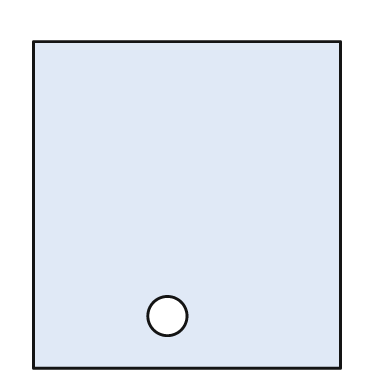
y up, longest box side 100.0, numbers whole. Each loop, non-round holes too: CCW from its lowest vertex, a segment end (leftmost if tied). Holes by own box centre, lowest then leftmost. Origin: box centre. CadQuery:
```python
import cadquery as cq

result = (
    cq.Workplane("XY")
    .moveTo(-47.0, -50.0)
    .lineTo(47.0, -50.0)
    .lineTo(47.0, 50.0)
    .lineTo(-47.0, 50.0)
    .close()
    .moveTo(-6.0, -34.0)
    .circle(6.0)
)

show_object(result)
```